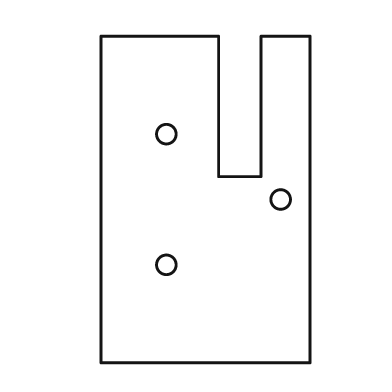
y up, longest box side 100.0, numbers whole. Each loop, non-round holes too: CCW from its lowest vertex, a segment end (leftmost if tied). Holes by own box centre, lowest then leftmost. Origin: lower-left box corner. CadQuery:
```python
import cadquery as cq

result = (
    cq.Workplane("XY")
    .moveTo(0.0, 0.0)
    .lineTo(64.0, 0.0)
    .lineTo(64.0, 100.0)
    .lineTo(49.0, 100.0)
    .lineTo(49.0, 57.0)
    .lineTo(36.0, 57.0)
    .lineTo(36.0, 100.0)
    .lineTo(0.0, 100.0)
    .close()
    .moveTo(20.0, 30.0)
    .circle(3.0)
    .moveTo(55.0, 50.0)
    .circle(3.0)
    .moveTo(20.0, 70.0)
    .circle(3.0)
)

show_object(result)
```